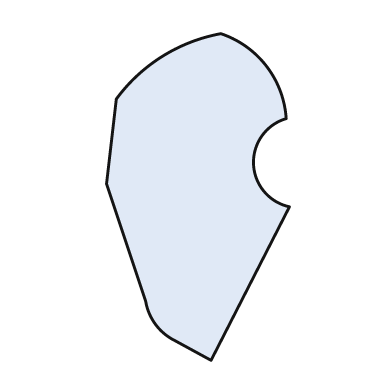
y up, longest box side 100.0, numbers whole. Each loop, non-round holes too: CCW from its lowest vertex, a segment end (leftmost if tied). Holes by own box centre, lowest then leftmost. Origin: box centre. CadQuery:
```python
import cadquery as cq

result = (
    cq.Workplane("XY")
    .moveTo(4.0, -50.0)
    .lineTo(28.0, -3.0)
    .threePointArc((17.0, 10.0), (27.0, 24.0))
    .threePointArc((21.0, 40.0), (7.0, 50.0))
    .threePointArc((-11.0, 43.0), (-25.0, 30.0))
    .lineTo(-28.0, 4.0)
    .lineTo(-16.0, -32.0)
    .threePointArc((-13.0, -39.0), (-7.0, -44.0))
    .close()
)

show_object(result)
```